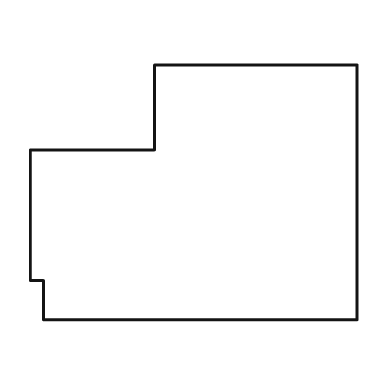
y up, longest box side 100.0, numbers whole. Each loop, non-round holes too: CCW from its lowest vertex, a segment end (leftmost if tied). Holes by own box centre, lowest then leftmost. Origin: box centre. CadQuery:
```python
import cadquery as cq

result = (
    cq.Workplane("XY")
    .moveTo(-46.0, -39.0)
    .lineTo(50.0, -39.0)
    .lineTo(50.0, 39.0)
    .lineTo(-12.0, 39.0)
    .lineTo(-12.0, 13.0)
    .lineTo(-50.0, 13.0)
    .lineTo(-50.0, -27.0)
    .lineTo(-46.0, -27.0)
    .close()
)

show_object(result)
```